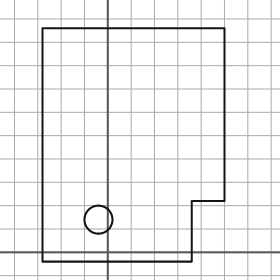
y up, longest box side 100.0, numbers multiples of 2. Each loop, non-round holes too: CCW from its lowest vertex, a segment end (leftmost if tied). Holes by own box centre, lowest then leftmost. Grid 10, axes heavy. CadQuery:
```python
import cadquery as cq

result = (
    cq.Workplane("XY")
    .moveTo(-28.0, -4.0)
    .lineTo(36.0, -4.0)
    .lineTo(36.0, 22.0)
    .lineTo(50.0, 22.0)
    .lineTo(50.0, 96.0)
    .lineTo(-28.0, 96.0)
    .close()
    .moveTo(-4.0, 14.0)
    .circle(6.0)
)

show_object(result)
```